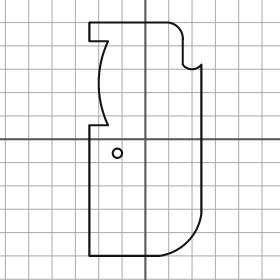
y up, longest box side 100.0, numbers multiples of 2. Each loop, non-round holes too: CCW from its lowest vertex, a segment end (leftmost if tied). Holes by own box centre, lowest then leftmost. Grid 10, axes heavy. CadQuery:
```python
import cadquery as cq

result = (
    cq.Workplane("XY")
    .moveTo(-24.0, -50.0)
    .lineTo(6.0, -50.0)
    .threePointArc((18.0, -44.0), (24.0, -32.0))
    .lineTo(24.0, 32.0)
    .threePointArc((20.0, 30.0), (16.0, 32.0))
    .lineTo(16.0, 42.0)
    .threePointArc((14.0, 48.0), (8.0, 50.0))
    .lineTo(-24.0, 50.0)
    .lineTo(-24.0, 42.0)
    .lineTo(-16.0, 42.0)
    .threePointArc((-20.0, 24.0), (-16.0, 6.0))
    .lineTo(-24.0, 6.0)
    .close()
    .moveTo(-12.0, -6.0)
    .circle(2.0)
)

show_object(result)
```